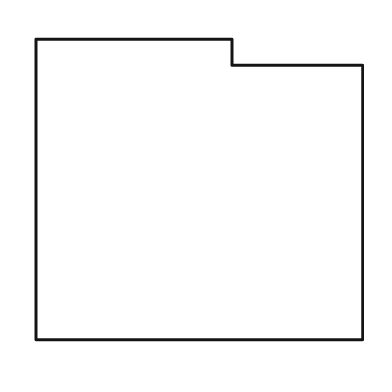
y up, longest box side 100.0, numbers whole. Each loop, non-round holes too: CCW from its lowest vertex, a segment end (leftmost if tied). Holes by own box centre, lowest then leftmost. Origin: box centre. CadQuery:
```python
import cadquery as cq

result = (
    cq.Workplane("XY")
    .moveTo(-50.0, -46.0)
    .lineTo(50.0, -46.0)
    .lineTo(50.0, 38.0)
    .lineTo(10.0, 38.0)
    .lineTo(10.0, 46.0)
    .lineTo(-50.0, 46.0)
    .close()
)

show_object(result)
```